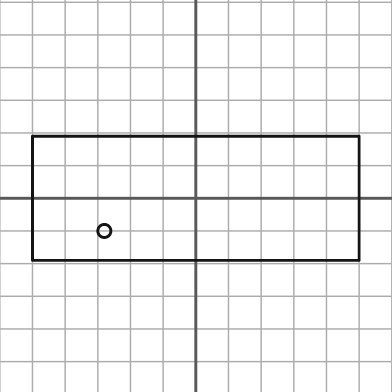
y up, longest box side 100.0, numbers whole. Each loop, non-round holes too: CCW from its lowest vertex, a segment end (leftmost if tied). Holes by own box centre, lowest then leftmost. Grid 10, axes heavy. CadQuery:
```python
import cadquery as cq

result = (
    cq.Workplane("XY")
    .moveTo(-50.0, -19.0)
    .lineTo(50.0, -19.0)
    .lineTo(50.0, 19.0)
    .lineTo(-50.0, 19.0)
    .close()
    .moveTo(-28.0, -10.0)
    .circle(2.0)
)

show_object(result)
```